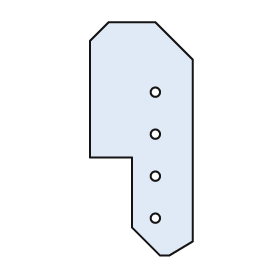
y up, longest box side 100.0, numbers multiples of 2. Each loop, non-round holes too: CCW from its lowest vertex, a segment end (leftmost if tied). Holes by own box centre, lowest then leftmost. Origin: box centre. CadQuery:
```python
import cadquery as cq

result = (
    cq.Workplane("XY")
    .moveTo(8.0, -50.0)
    .lineTo(12.0, -50.0)
    .lineTo(22.0, -44.0)
    .lineTo(22.0, 34.0)
    .lineTo(6.0, 50.0)
    .lineTo(-14.0, 50.0)
    .lineTo(-22.0, 42.0)
    .lineTo(-22.0, -8.0)
    .lineTo(-4.0, -8.0)
    .lineTo(-4.0, -38.0)
    .close()
    .moveTo(6.0, -34.0)
    .circle(2.0)
    .moveTo(6.0, -16.0)
    .circle(2.0)
    .moveTo(6.0, 2.0)
    .circle(2.0)
    .moveTo(6.0, 20.0)
    .circle(2.0)
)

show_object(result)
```